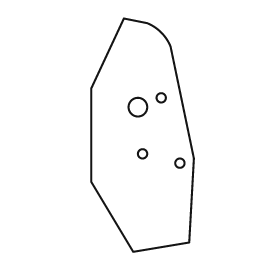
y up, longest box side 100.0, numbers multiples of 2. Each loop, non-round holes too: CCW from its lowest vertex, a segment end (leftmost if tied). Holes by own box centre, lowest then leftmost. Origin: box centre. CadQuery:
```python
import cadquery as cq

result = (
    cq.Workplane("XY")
    .moveTo(-4.0, -50.0)
    .lineTo(20.0, -46.0)
    .lineTo(22.0, -10.0)
    .lineTo(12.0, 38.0)
    .threePointArc((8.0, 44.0), (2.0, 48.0))
    .lineTo(-8.0, 50.0)
    .lineTo(-22.0, 20.0)
    .lineTo(-22.0, -20.0)
    .close()
    .moveTo(16.0, -12.0)
    .circle(2.0)
    .moveTo(0.0, -8.0)
    .circle(2.0)
    .moveTo(-2.0, 12.0)
    .circle(4.0)
    .moveTo(8.0, 16.0)
    .circle(2.0)
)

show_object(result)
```